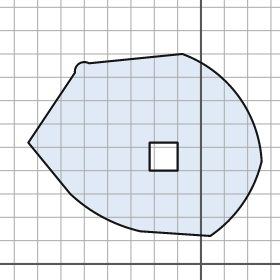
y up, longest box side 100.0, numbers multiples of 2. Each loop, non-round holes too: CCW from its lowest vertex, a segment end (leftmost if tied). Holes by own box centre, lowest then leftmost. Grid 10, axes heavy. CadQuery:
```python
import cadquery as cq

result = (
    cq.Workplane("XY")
    .moveTo(4.0, 12.0)
    .threePointArc((18.0, 26.0), (26.0, 44.0))
    .threePointArc((16.0, 72.0), (-8.0, 90.0))
    .lineTo(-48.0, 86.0)
    .threePointArc((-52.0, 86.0), (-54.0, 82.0))
    .lineTo(-74.0, 52.0)
    .lineTo(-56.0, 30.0)
    .threePointArc((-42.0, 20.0), (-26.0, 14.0))
    .close()
    .moveTo(-22.0, 40.0)
    .lineTo(-10.0, 40.0)
    .lineTo(-10.0, 52.0)
    .lineTo(-22.0, 52.0)
    .close()
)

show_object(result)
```